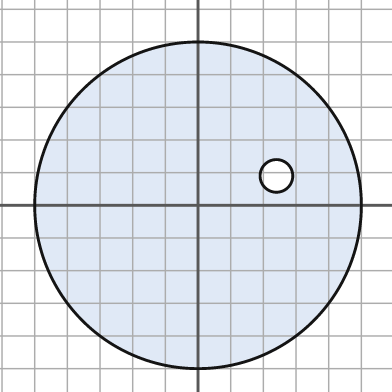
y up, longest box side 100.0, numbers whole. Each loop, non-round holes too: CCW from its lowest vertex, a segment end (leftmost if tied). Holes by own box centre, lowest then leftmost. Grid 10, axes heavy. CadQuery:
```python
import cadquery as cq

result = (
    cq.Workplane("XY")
    .moveTo(0.0, 0.0)
    .circle(50.0)
    .moveTo(24.0, 9.0)
    .circle(5.0)
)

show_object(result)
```